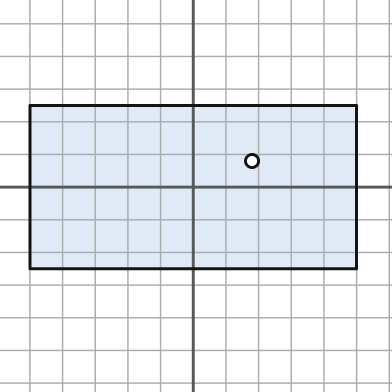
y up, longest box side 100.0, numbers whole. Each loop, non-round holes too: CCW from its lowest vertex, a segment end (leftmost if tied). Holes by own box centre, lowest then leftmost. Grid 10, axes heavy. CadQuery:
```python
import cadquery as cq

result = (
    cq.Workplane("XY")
    .moveTo(-50.0, -25.0)
    .lineTo(50.0, -25.0)
    .lineTo(50.0, 25.0)
    .lineTo(-50.0, 25.0)
    .close()
    .moveTo(18.0, 8.0)
    .circle(2.0)
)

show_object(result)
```